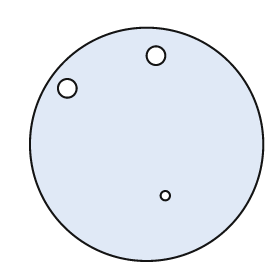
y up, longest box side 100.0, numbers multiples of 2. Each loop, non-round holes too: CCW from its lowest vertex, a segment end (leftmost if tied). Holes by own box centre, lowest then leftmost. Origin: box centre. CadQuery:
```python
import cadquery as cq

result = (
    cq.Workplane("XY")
    .moveTo(0.0, 0.0)
    .circle(50.0)
    .moveTo(8.0, -22.0)
    .circle(2.0)
    .moveTo(-34.0, 24.0)
    .circle(4.0)
    .moveTo(4.0, 38.0)
    .circle(4.0)
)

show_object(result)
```